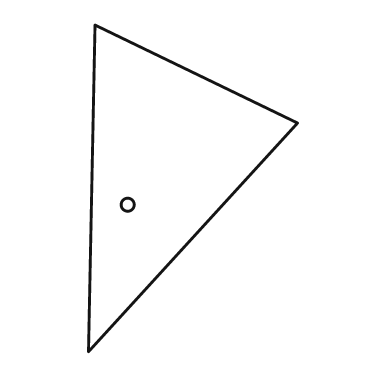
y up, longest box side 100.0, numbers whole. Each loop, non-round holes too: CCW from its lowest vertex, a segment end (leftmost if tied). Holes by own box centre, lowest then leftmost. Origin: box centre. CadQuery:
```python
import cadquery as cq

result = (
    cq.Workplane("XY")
    .moveTo(-32.0, -50.0)
    .lineTo(32.0, 20.0)
    .lineTo(-30.0, 50.0)
    .close()
    .moveTo(-20.0, -5.0)
    .circle(2.0)
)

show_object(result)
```